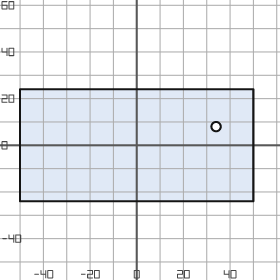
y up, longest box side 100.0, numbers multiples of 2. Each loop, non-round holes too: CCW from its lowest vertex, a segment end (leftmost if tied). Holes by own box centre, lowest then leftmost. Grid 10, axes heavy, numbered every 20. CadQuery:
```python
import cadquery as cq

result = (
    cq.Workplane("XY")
    .moveTo(-50.0, -24.0)
    .lineTo(50.0, -24.0)
    .lineTo(50.0, 24.0)
    .lineTo(-50.0, 24.0)
    .close()
    .moveTo(34.0, 8.0)
    .circle(2.0)
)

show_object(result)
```